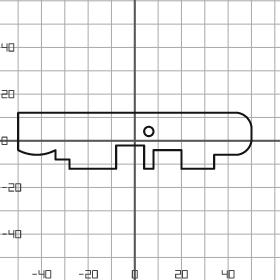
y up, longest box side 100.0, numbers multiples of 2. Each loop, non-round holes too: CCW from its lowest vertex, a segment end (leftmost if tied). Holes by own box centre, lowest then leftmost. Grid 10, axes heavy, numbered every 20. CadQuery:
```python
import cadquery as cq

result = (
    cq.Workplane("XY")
    .moveTo(-28.0, -12.0)
    .lineTo(-8.0, -12.0)
    .lineTo(-8.0, -2.0)
    .lineTo(4.0, -2.0)
    .lineTo(4.0, -12.0)
    .lineTo(8.0, -12.0)
    .lineTo(8.0, -4.0)
    .lineTo(20.0, -4.0)
    .lineTo(20.0, -12.0)
    .lineTo(34.0, -12.0)
    .lineTo(34.0, -6.0)
    .lineTo(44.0, -6.0)
    .threePointArc((48.0, -4.0), (50.0, 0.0))
    .lineTo(50.0, 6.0)
    .threePointArc((48.0, 10.0), (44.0, 12.0))
    .lineTo(-50.0, 12.0)
    .lineTo(-50.0, -4.0)
    .threePointArc((-42.0, -6.0), (-34.0, -4.0))
    .lineTo(-34.0, -8.0)
    .lineTo(-28.0, -8.0)
    .close()
    .moveTo(6.0, 4.0)
    .circle(2.0)
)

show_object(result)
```